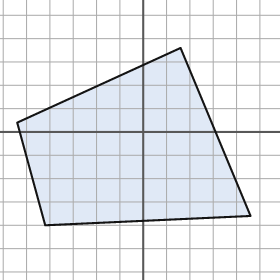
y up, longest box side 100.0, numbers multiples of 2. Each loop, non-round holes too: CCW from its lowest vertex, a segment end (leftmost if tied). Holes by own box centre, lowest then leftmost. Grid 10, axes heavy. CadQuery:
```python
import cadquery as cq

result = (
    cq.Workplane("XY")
    .moveTo(-42.0, -40.0)
    .lineTo(46.0, -36.0)
    .lineTo(16.0, 36.0)
    .lineTo(-54.0, 4.0)
    .close()
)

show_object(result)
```